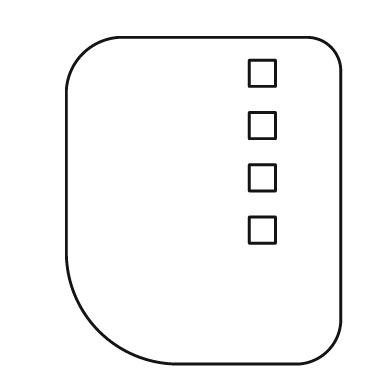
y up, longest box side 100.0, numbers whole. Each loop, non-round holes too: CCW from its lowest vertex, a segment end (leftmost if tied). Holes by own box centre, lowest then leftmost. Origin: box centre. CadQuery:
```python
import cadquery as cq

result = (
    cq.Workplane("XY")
    .moveTo(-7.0, -50.0)
    .lineTo(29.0, -50.0)
    .threePointArc((38.0, -46.0), (42.0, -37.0))
    .lineTo(42.0, 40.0)
    .threePointArc((39.0, 47.0), (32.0, 50.0))
    .lineTo(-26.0, 50.0)
    .threePointArc((-37.0, 45.0), (-42.0, 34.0))
    .lineTo(-42.0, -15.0)
    .threePointArc((-32.0, -40.0), (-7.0, -50.0))
    .close()
    .moveTo(14.0, -13.0)
    .lineTo(22.0, -13.0)
    .lineTo(22.0, -5.0)
    .lineTo(14.0, -5.0)
    .close()
    .moveTo(14.0, 3.0)
    .lineTo(22.0, 3.0)
    .lineTo(22.0, 11.0)
    .lineTo(14.0, 11.0)
    .close()
    .moveTo(14.0, 19.0)
    .lineTo(22.0, 19.0)
    .lineTo(22.0, 27.0)
    .lineTo(14.0, 27.0)
    .close()
    .moveTo(14.0, 35.0)
    .lineTo(22.0, 35.0)
    .lineTo(22.0, 43.0)
    .lineTo(14.0, 43.0)
    .close()
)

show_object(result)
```